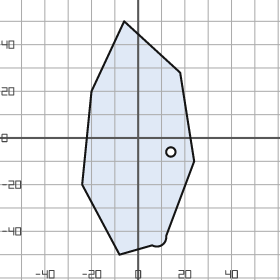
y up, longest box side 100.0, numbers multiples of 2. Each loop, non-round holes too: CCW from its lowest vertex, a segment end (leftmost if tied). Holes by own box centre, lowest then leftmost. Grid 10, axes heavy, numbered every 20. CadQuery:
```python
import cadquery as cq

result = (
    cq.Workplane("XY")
    .moveTo(-8.0, -50.0)
    .lineTo(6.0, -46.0)
    .threePointArc((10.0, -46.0), (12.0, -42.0))
    .lineTo(24.0, -10.0)
    .lineTo(18.0, 28.0)
    .lineTo(-6.0, 50.0)
    .lineTo(-20.0, 20.0)
    .lineTo(-24.0, -20.0)
    .close()
    .moveTo(14.0, -6.0)
    .circle(2.0)
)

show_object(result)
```